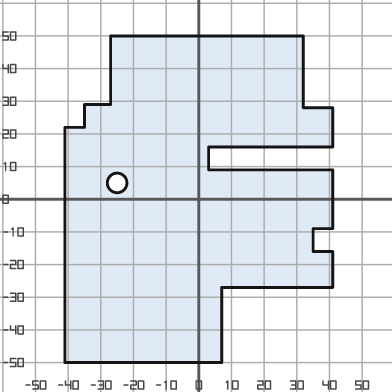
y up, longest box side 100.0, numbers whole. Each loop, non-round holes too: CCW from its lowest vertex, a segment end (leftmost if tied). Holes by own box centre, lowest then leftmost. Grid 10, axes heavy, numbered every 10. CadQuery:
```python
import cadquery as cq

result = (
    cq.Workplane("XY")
    .moveTo(-41.0, -50.0)
    .lineTo(7.0, -50.0)
    .lineTo(7.0, -27.0)
    .lineTo(41.0, -27.0)
    .lineTo(41.0, -16.0)
    .lineTo(35.0, -16.0)
    .lineTo(35.0, -9.0)
    .lineTo(41.0, -9.0)
    .lineTo(41.0, 9.0)
    .lineTo(3.0, 9.0)
    .lineTo(3.0, 16.0)
    .lineTo(41.0, 16.0)
    .lineTo(41.0, 28.0)
    .lineTo(32.0, 28.0)
    .lineTo(32.0, 50.0)
    .lineTo(-27.0, 50.0)
    .lineTo(-27.0, 29.0)
    .lineTo(-35.0, 29.0)
    .lineTo(-35.0, 22.0)
    .lineTo(-41.0, 22.0)
    .close()
    .moveTo(-25.0, 5.0)
    .circle(3.0)
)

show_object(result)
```